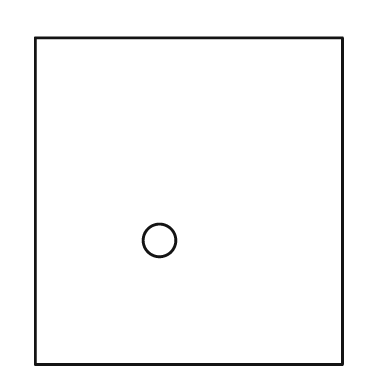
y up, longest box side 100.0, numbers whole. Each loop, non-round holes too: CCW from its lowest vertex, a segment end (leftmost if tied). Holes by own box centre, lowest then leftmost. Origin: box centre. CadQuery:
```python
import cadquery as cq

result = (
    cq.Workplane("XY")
    .moveTo(-47.0, -50.0)
    .lineTo(47.0, -50.0)
    .lineTo(47.0, 50.0)
    .lineTo(-47.0, 50.0)
    .close()
    .moveTo(-9.0, -12.0)
    .circle(5.0)
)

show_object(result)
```